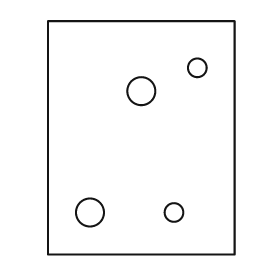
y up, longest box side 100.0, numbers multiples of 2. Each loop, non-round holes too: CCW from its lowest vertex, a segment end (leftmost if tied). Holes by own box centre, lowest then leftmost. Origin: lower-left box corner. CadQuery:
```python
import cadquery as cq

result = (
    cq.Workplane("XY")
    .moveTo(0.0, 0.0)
    .lineTo(80.0, 0.0)
    .lineTo(80.0, 100.0)
    .lineTo(0.0, 100.0)
    .close()
    .moveTo(18.0, 18.0)
    .circle(6.0)
    .moveTo(54.0, 18.0)
    .circle(4.0)
    .moveTo(40.0, 70.0)
    .circle(6.0)
    .moveTo(64.0, 80.0)
    .circle(4.0)
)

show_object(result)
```